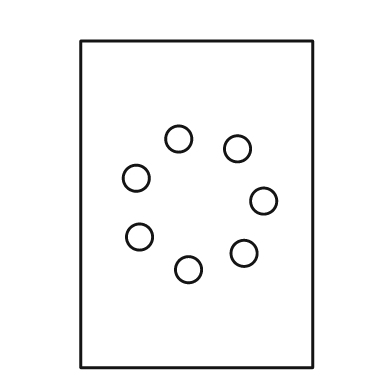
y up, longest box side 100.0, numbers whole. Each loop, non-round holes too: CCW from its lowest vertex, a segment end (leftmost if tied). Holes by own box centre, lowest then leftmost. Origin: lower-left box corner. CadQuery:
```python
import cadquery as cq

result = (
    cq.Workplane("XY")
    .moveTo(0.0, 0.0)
    .lineTo(71.0, 0.0)
    .lineTo(71.0, 100.0)
    .lineTo(0.0, 100.0)
    .close()
    .moveTo(33.0, 30.0)
    .circle(4.0)
    .moveTo(50.0, 35.0)
    .circle(4.0)
    .moveTo(18.0, 40.0)
    .circle(4.0)
    .moveTo(56.0, 51.0)
    .circle(4.0)
    .moveTo(17.0, 58.0)
    .circle(4.0)
    .moveTo(48.0, 67.0)
    .circle(4.0)
    .moveTo(30.0, 70.0)
    .circle(4.0)
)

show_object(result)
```